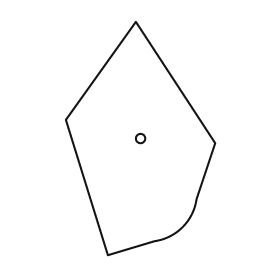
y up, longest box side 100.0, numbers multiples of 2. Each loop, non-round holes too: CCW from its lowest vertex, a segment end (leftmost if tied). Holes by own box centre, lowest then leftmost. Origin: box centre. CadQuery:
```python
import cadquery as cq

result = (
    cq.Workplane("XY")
    .moveTo(-14.0, -50.0)
    .lineTo(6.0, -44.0)
    .threePointArc((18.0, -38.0), (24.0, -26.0))
    .lineTo(32.0, -2.0)
    .lineTo(-2.0, 50.0)
    .lineTo(-32.0, 8.0)
    .close()
    .moveTo(0.0, 0.0)
    .circle(2.0)
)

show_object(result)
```